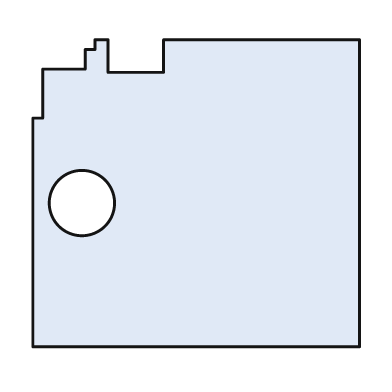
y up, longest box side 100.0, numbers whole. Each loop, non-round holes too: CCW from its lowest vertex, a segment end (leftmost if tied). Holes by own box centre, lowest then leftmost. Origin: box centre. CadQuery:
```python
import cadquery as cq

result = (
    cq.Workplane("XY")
    .moveTo(-50.0, -47.0)
    .lineTo(50.0, -47.0)
    .lineTo(50.0, 47.0)
    .lineTo(-10.0, 47.0)
    .lineTo(-10.0, 37.0)
    .lineTo(-27.0, 37.0)
    .lineTo(-27.0, 47.0)
    .lineTo(-31.0, 47.0)
    .lineTo(-31.0, 44.0)
    .lineTo(-34.0, 44.0)
    .lineTo(-34.0, 38.0)
    .lineTo(-47.0, 38.0)
    .lineTo(-47.0, 23.0)
    .lineTo(-50.0, 23.0)
    .close()
    .moveTo(-35.0, -3.0)
    .circle(10.0)
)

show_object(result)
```